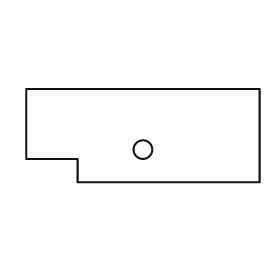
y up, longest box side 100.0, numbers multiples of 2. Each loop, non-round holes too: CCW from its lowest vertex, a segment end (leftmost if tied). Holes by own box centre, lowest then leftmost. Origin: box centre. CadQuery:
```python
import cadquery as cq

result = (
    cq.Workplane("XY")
    .moveTo(-28.0, -20.0)
    .lineTo(50.0, -20.0)
    .lineTo(50.0, 20.0)
    .lineTo(-50.0, 20.0)
    .lineTo(-50.0, -10.0)
    .lineTo(-28.0, -10.0)
    .close()
    .moveTo(0.0, -6.0)
    .circle(4.0)
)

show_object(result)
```